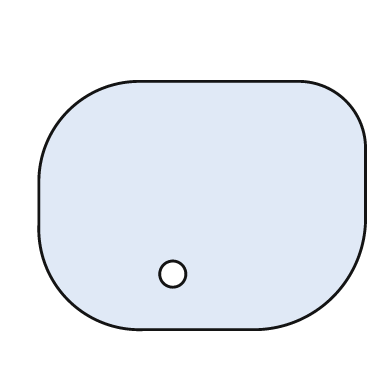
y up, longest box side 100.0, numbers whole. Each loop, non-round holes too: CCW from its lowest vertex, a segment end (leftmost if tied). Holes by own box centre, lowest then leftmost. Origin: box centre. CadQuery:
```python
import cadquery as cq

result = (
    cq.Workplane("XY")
    .moveTo(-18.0, -38.0)
    .lineTo(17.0, -38.0)
    .threePointArc((40.0, -28.0), (50.0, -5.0))
    .lineTo(50.0, 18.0)
    .threePointArc((44.0, 32.0), (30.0, 38.0))
    .lineTo(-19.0, 38.0)
    .threePointArc((-41.0, 29.0), (-50.0, 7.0))
    .lineTo(-50.0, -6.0)
    .threePointArc((-41.0, -29.0), (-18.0, -38.0))
    .close()
    .moveTo(-9.0, -21.0)
    .circle(4.0)
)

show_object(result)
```